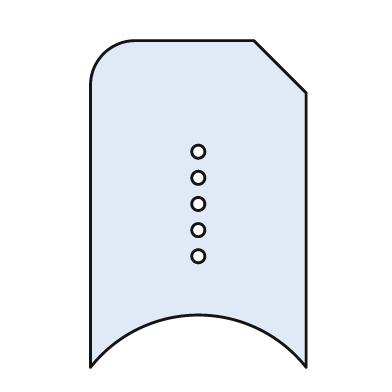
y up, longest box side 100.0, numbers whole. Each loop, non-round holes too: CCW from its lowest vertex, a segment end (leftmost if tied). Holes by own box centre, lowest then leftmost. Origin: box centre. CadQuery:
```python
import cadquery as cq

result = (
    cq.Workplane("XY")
    .moveTo(-33.0, -50.0)
    .threePointArc((0.0, -34.0), (33.0, -50.0))
    .lineTo(33.0, 34.0)
    .lineTo(17.0, 50.0)
    .lineTo(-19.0, 50.0)
    .threePointArc((-29.0, 46.0), (-33.0, 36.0))
    .close()
    .moveTo(0.0, -16.0)
    .circle(2.0)
    .moveTo(0.0, -8.0)
    .circle(2.0)
    .moveTo(0.0, 0.0)
    .circle(2.0)
    .moveTo(0.0, 8.0)
    .circle(2.0)
    .moveTo(0.0, 16.0)
    .circle(2.0)
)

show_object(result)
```